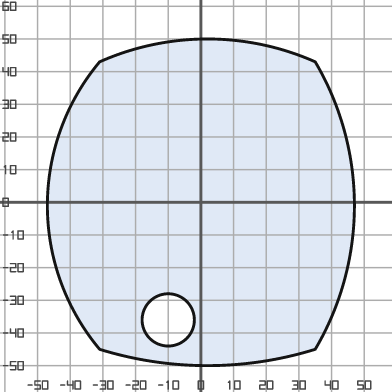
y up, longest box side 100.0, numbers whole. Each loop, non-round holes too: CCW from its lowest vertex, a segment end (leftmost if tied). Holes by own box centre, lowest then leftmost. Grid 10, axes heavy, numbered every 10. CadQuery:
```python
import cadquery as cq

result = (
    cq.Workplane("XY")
    .moveTo(-31.0, -45.0)
    .threePointArc((2.0, -50.0), (35.0, -45.0))
    .threePointArc((47.0, -1.0), (35.0, 43.0))
    .threePointArc((2.0, 50.0), (-31.0, 43.0))
    .threePointArc((-47.0, -1.0), (-31.0, -45.0))
    .close()
    .moveTo(-10.0, -36.0)
    .circle(8.0)
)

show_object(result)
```